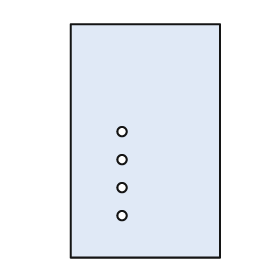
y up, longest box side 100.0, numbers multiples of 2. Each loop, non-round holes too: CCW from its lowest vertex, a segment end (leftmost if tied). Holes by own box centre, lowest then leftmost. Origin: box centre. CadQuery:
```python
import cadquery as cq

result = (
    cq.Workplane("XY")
    .moveTo(-32.0, -50.0)
    .lineTo(32.0, -50.0)
    .lineTo(32.0, 50.0)
    .lineTo(-32.0, 50.0)
    .close()
    .moveTo(-10.0, -32.0)
    .circle(2.0)
    .moveTo(-10.0, -20.0)
    .circle(2.0)
    .moveTo(-10.0, -8.0)
    .circle(2.0)
    .moveTo(-10.0, 4.0)
    .circle(2.0)
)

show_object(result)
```